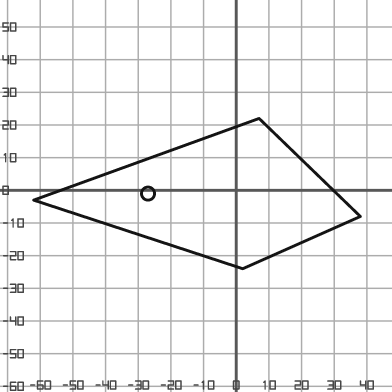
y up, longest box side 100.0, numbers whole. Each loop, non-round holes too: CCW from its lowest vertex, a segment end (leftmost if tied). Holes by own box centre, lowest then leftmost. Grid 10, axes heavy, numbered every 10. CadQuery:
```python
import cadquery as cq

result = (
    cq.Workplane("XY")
    .moveTo(2.0, -24.0)
    .lineTo(38.0, -8.0)
    .lineTo(7.0, 22.0)
    .lineTo(-62.0, -3.0)
    .close()
    .moveTo(-27.0, -1.0)
    .circle(2.0)
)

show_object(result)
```